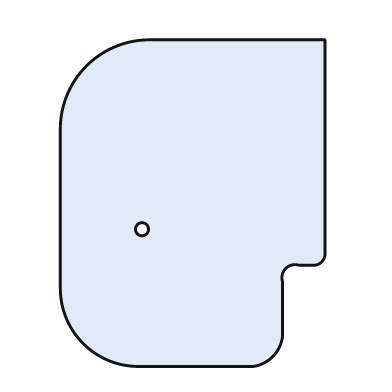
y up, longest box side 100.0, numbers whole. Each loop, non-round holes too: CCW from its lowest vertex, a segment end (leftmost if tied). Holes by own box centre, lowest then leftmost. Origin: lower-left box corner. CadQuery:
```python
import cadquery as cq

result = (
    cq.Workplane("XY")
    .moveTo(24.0, 0.0)
    .lineTo(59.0, 0.0)
    .threePointArc((65.0, 3.0), (68.0, 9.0))
    .lineTo(68.0, 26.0)
    .threePointArc((69.0, 30.0), (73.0, 31.0))
    .lineTo(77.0, 31.0)
    .threePointArc((80.0, 32.0), (81.0, 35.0))
    .lineTo(81.0, 100.0)
    .lineTo(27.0, 100.0)
    .threePointArc((8.0, 92.0), (0.0, 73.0))
    .lineTo(0.0, 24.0)
    .threePointArc((7.0, 7.0), (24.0, 0.0))
    .close()
    .moveTo(25.0, 42.0)
    .circle(2.0)
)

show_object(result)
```